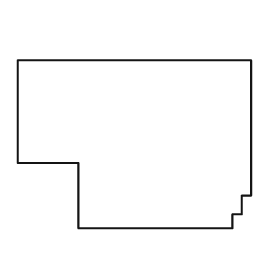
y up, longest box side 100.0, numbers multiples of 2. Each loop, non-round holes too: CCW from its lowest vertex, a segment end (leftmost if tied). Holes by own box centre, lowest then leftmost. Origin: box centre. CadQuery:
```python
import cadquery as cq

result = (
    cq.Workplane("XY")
    .moveTo(-24.0, -36.0)
    .lineTo(42.0, -36.0)
    .lineTo(42.0, -30.0)
    .lineTo(46.0, -30.0)
    .lineTo(46.0, -22.0)
    .lineTo(50.0, -22.0)
    .lineTo(50.0, 36.0)
    .lineTo(-50.0, 36.0)
    .lineTo(-50.0, -8.0)
    .lineTo(-24.0, -8.0)
    .close()
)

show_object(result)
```